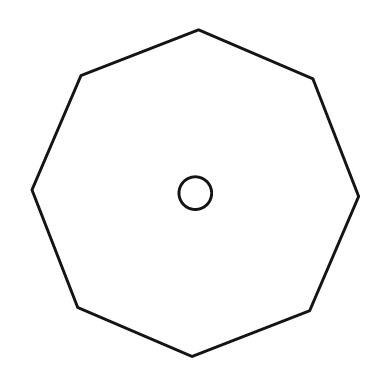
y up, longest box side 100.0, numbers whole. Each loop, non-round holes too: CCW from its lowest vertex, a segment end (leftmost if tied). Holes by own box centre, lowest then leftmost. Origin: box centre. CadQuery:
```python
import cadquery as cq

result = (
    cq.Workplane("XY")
    .moveTo(-1.0, -50.0)
    .lineTo(35.0, -36.0)
    .lineTo(50.0, -1.0)
    .lineTo(36.0, 35.0)
    .lineTo(1.0, 50.0)
    .lineTo(-35.0, 36.0)
    .lineTo(-50.0, 1.0)
    .lineTo(-36.0, -35.0)
    .close()
    .moveTo(0.0, 0.0)
    .circle(5.0)
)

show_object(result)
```